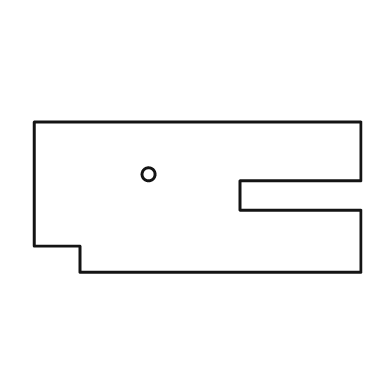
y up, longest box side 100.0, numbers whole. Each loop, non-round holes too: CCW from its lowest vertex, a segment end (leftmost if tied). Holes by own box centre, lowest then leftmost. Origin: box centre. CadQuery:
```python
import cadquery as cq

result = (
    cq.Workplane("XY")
    .moveTo(-36.0, -23.0)
    .lineTo(50.0, -23.0)
    .lineTo(50.0, -4.0)
    .lineTo(13.0, -4.0)
    .lineTo(13.0, 5.0)
    .lineTo(50.0, 5.0)
    .lineTo(50.0, 23.0)
    .lineTo(-50.0, 23.0)
    .lineTo(-50.0, -15.0)
    .lineTo(-36.0, -15.0)
    .close()
    .moveTo(-15.0, 7.0)
    .circle(2.0)
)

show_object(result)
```